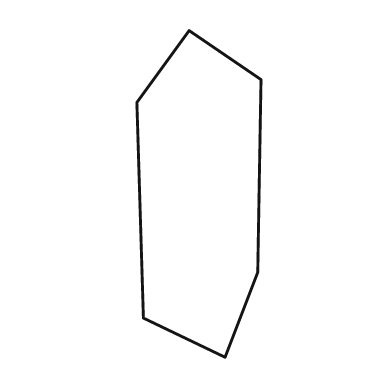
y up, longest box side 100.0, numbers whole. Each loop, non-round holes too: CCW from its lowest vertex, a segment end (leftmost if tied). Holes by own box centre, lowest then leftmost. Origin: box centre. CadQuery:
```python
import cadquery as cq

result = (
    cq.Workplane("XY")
    .moveTo(8.0, -50.0)
    .lineTo(18.0, -24.0)
    .lineTo(19.0, 35.0)
    .lineTo(-3.0, 50.0)
    .lineTo(-19.0, 28.0)
    .lineTo(-17.0, -38.0)
    .close()
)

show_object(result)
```